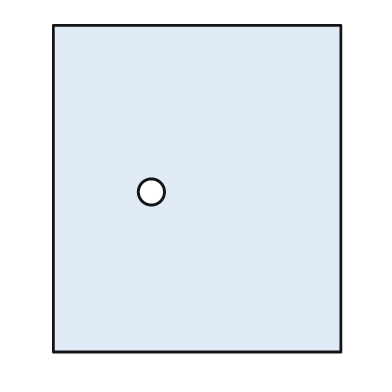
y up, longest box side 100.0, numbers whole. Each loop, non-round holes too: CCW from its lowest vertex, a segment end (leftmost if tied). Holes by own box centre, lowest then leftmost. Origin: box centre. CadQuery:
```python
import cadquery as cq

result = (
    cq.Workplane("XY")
    .moveTo(-44.0, -50.0)
    .lineTo(44.0, -50.0)
    .lineTo(44.0, 50.0)
    .lineTo(-44.0, 50.0)
    .close()
    .moveTo(-14.0, -1.0)
    .circle(4.0)
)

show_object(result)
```